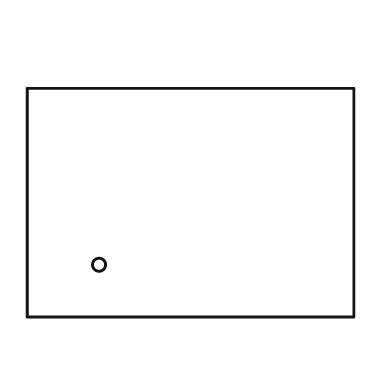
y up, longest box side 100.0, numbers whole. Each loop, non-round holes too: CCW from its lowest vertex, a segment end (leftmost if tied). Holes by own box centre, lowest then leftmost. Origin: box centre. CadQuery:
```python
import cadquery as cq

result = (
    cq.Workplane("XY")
    .moveTo(-50.0, -35.0)
    .lineTo(50.0, -35.0)
    .lineTo(50.0, 35.0)
    .lineTo(-50.0, 35.0)
    .close()
    .moveTo(-28.0, -19.0)
    .circle(2.0)
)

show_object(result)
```